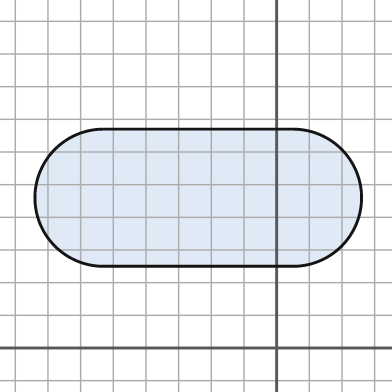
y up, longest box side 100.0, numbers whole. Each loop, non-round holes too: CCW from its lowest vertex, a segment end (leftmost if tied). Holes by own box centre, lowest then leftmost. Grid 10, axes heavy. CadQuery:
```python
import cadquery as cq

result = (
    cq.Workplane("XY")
    .moveTo(-53.0, 25.0)
    .lineTo(5.0, 25.0)
    .threePointArc((26.0, 46.0), (5.0, 67.0))
    .lineTo(-53.0, 67.0)
    .threePointArc((-74.0, 46.0), (-53.0, 25.0))
    .close()
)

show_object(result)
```